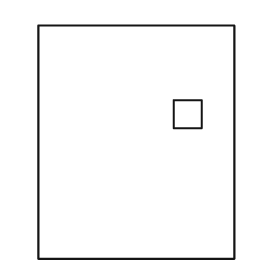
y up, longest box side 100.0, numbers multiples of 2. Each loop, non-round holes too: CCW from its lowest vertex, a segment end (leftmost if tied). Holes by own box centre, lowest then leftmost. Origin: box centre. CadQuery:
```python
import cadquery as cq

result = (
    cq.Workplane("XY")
    .moveTo(-42.0, -50.0)
    .lineTo(42.0, -50.0)
    .lineTo(42.0, 50.0)
    .lineTo(-42.0, 50.0)
    .close()
    .moveTo(16.0, 6.0)
    .lineTo(28.0, 6.0)
    .lineTo(28.0, 18.0)
    .lineTo(16.0, 18.0)
    .close()
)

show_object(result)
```